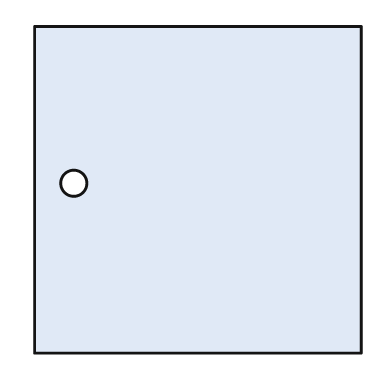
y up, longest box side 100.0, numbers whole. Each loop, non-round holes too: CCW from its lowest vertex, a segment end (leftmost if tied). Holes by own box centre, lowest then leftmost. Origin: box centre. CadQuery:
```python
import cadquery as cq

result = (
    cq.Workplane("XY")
    .moveTo(-50.0, -50.0)
    .lineTo(50.0, -50.0)
    .lineTo(50.0, 50.0)
    .lineTo(-50.0, 50.0)
    .close()
    .moveTo(-38.0, 2.0)
    .circle(4.0)
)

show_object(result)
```